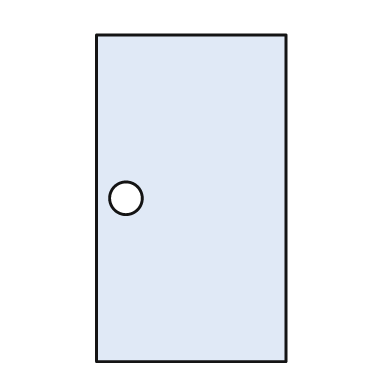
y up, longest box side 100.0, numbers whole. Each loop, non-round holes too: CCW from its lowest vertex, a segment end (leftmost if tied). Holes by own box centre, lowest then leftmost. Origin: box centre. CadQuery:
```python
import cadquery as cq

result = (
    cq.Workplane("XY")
    .moveTo(-29.0, -50.0)
    .lineTo(29.0, -50.0)
    .lineTo(29.0, 50.0)
    .lineTo(-29.0, 50.0)
    .close()
    .moveTo(-20.0, 0.0)
    .circle(5.0)
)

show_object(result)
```